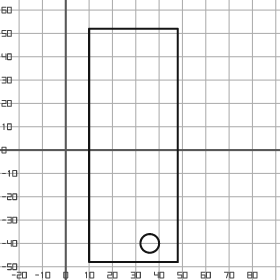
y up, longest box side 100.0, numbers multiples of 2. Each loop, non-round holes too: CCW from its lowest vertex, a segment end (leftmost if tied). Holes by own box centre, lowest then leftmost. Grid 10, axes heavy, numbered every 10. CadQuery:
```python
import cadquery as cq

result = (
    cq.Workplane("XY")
    .moveTo(10.0, -48.0)
    .lineTo(48.0, -48.0)
    .lineTo(48.0, 52.0)
    .lineTo(10.0, 52.0)
    .close()
    .moveTo(36.0, -40.0)
    .circle(4.0)
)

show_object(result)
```